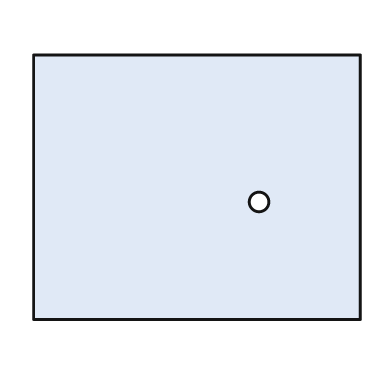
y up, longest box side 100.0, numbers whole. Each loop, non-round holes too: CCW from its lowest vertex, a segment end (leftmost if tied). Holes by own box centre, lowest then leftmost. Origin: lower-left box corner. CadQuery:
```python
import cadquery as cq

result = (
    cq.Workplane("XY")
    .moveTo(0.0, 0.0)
    .lineTo(100.0, 0.0)
    .lineTo(100.0, 81.0)
    .lineTo(0.0, 81.0)
    .close()
    .moveTo(69.0, 36.0)
    .circle(3.0)
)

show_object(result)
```